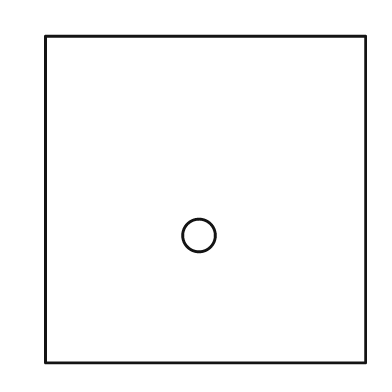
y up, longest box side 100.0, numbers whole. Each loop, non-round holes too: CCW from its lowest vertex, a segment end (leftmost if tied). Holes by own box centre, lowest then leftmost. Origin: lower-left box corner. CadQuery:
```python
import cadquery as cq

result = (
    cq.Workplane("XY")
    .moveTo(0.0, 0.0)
    .lineTo(98.0, 0.0)
    .lineTo(98.0, 100.0)
    .lineTo(0.0, 100.0)
    .close()
    .moveTo(47.0, 39.0)
    .circle(5.0)
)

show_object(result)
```